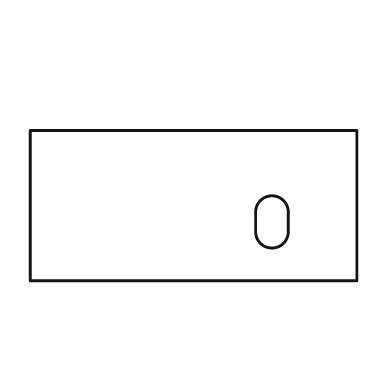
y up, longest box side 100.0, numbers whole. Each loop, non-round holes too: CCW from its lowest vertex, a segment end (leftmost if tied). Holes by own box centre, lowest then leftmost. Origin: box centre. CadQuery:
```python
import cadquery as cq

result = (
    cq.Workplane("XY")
    .moveTo(-50.0, -23.0)
    .lineTo(50.0, -23.0)
    .lineTo(50.0, 23.0)
    .lineTo(-50.0, 23.0)
    .close()
    .moveTo(19.0, -8.0)
    .threePointArc((24.0, -13.0), (29.0, -8.0))
    .lineTo(29.0, -2.0)
    .threePointArc((24.0, 3.0), (19.0, -2.0))
    .close()
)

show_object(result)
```